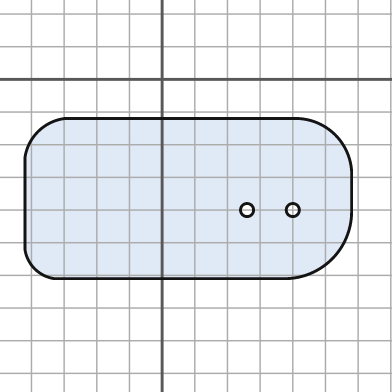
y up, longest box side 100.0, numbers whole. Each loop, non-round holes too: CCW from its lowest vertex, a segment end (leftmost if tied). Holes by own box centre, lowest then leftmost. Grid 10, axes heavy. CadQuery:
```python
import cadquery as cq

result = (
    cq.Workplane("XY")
    .moveTo(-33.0, -61.0)
    .lineTo(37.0, -61.0)
    .threePointArc((52.0, -55.0), (58.0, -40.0))
    .lineTo(58.0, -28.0)
    .threePointArc((53.0, -17.0), (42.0, -12.0))
    .lineTo(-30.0, -12.0)
    .threePointArc((-38.0, -16.0), (-42.0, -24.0))
    .lineTo(-42.0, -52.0)
    .threePointArc((-39.0, -58.0), (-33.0, -61.0))
    .close()
    .moveTo(26.0, -40.0)
    .circle(2.0)
    .moveTo(40.0, -40.0)
    .circle(2.0)
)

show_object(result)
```